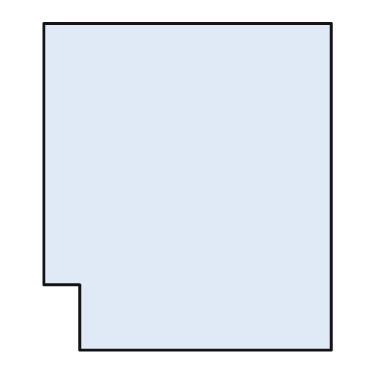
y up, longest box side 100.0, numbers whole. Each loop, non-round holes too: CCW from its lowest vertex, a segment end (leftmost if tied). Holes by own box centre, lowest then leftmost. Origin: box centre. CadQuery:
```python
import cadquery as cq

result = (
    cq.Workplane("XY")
    .moveTo(-33.0, -50.0)
    .lineTo(44.0, -50.0)
    .lineTo(44.0, 50.0)
    .lineTo(-44.0, 50.0)
    .lineTo(-44.0, -30.0)
    .lineTo(-33.0, -30.0)
    .close()
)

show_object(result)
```